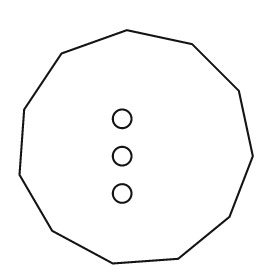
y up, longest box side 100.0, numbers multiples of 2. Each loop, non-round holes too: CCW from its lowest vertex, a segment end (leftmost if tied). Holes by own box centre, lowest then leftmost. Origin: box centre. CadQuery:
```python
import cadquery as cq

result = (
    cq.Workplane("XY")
    .moveTo(-10.0, -50.0)
    .lineTo(18.0, -48.0)
    .lineTo(40.0, -30.0)
    .lineTo(50.0, -4.0)
    .lineTo(44.0, 24.0)
    .lineTo(24.0, 44.0)
    .lineTo(-4.0, 50.0)
    .lineTo(-32.0, 40.0)
    .lineTo(-48.0, 16.0)
    .lineTo(-50.0, -12.0)
    .lineTo(-36.0, -36.0)
    .close()
    .moveTo(-6.0, -20.0)
    .circle(4.0)
    .moveTo(-6.0, -4.0)
    .circle(4.0)
    .moveTo(-6.0, 12.0)
    .circle(4.0)
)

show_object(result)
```